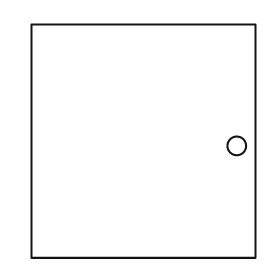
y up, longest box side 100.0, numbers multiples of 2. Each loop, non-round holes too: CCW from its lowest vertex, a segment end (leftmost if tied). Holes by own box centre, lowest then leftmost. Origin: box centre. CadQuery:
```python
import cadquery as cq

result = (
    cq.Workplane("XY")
    .moveTo(-48.0, -50.0)
    .lineTo(48.0, -50.0)
    .lineTo(48.0, 50.0)
    .lineTo(-48.0, 50.0)
    .close()
    .moveTo(40.0, -2.0)
    .circle(4.0)
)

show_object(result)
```